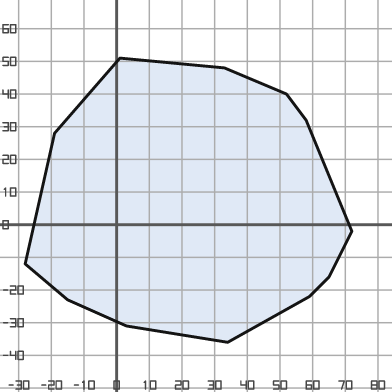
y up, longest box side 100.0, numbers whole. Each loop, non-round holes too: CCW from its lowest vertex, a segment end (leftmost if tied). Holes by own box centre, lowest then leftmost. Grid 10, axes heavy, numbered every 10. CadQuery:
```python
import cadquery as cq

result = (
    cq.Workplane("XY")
    .moveTo(34.0, -36.0)
    .lineTo(59.0, -22.0)
    .lineTo(65.0, -16.0)
    .lineTo(72.0, -2.0)
    .lineTo(58.0, 32.0)
    .lineTo(52.0, 40.0)
    .lineTo(33.0, 48.0)
    .lineTo(1.0, 51.0)
    .lineTo(-19.0, 28.0)
    .lineTo(-28.0, -12.0)
    .lineTo(-15.0, -23.0)
    .lineTo(3.0, -31.0)
    .close()
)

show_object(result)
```